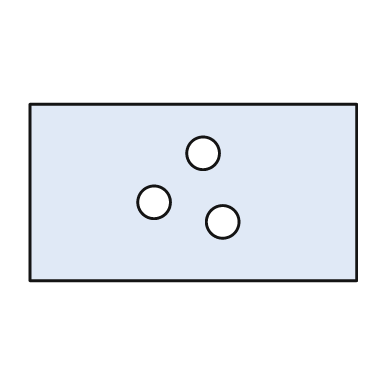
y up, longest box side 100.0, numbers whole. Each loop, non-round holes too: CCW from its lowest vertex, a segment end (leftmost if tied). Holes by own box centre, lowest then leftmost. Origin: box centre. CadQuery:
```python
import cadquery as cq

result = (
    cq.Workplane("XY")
    .moveTo(-50.0, -27.0)
    .lineTo(50.0, -27.0)
    .lineTo(50.0, 27.0)
    .lineTo(-50.0, 27.0)
    .close()
    .moveTo(9.0, -9.0)
    .circle(5.0)
    .moveTo(-12.0, -3.0)
    .circle(5.0)
    .moveTo(3.0, 12.0)
    .circle(5.0)
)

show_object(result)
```